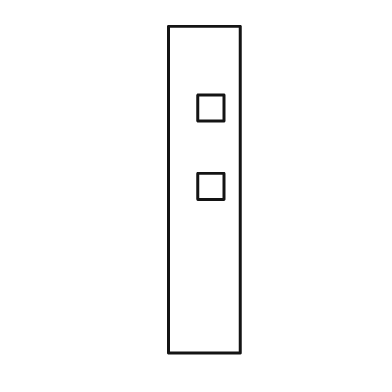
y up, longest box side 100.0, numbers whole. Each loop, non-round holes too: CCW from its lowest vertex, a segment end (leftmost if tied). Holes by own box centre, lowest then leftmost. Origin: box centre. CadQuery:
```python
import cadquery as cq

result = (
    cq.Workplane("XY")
    .moveTo(-11.0, -50.0)
    .lineTo(11.0, -50.0)
    .lineTo(11.0, 50.0)
    .lineTo(-11.0, 50.0)
    .close()
    .moveTo(-2.0, -3.0)
    .lineTo(6.0, -3.0)
    .lineTo(6.0, 5.0)
    .lineTo(-2.0, 5.0)
    .close()
    .moveTo(-2.0, 21.0)
    .lineTo(6.0, 21.0)
    .lineTo(6.0, 29.0)
    .lineTo(-2.0, 29.0)
    .close()
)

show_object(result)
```